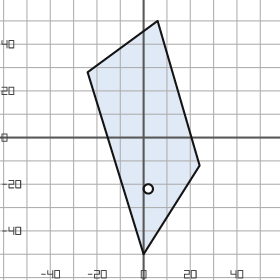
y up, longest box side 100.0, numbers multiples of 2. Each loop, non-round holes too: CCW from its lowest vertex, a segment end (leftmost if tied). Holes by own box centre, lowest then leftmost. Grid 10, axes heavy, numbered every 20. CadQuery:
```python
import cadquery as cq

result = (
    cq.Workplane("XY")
    .moveTo(0.0, -50.0)
    .lineTo(24.0, -12.0)
    .lineTo(6.0, 50.0)
    .lineTo(-24.0, 28.0)
    .close()
    .moveTo(2.0, -22.0)
    .circle(2.0)
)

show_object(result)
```